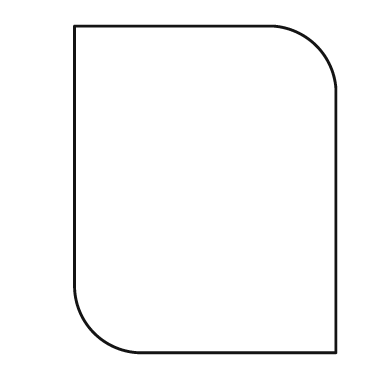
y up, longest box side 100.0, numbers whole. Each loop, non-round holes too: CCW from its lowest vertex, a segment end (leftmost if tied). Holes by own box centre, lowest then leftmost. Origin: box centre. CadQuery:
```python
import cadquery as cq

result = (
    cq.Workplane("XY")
    .moveTo(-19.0, -50.0)
    .lineTo(40.0, -50.0)
    .lineTo(40.0, 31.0)
    .threePointArc((34.0, 44.0), (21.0, 50.0))
    .lineTo(-40.0, 50.0)
    .lineTo(-40.0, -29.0)
    .threePointArc((-34.0, -44.0), (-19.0, -50.0))
    .close()
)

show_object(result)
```